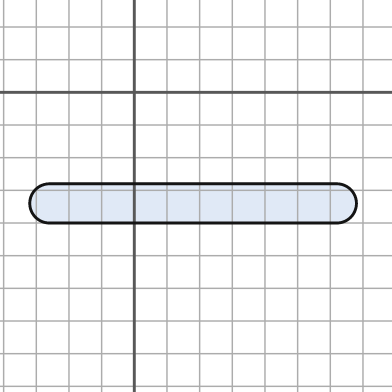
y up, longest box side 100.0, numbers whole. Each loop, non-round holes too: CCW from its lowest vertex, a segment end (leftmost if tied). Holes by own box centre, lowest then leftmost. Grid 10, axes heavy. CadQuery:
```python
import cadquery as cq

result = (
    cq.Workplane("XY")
    .moveTo(-26.0, -40.0)
    .lineTo(62.0, -40.0)
    .threePointArc((68.0, -34.0), (62.0, -28.0))
    .lineTo(-26.0, -28.0)
    .threePointArc((-32.0, -34.0), (-26.0, -40.0))
    .close()
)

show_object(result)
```